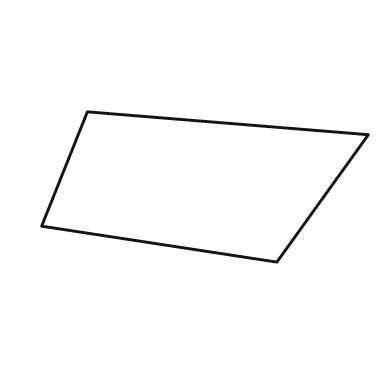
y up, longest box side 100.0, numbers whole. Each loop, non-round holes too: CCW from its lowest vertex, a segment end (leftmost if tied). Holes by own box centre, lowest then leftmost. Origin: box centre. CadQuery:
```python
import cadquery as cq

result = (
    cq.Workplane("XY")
    .moveTo(22.0, -23.0)
    .lineTo(50.0, 16.0)
    .lineTo(-36.0, 23.0)
    .lineTo(-50.0, -12.0)
    .close()
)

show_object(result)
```